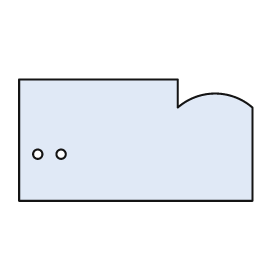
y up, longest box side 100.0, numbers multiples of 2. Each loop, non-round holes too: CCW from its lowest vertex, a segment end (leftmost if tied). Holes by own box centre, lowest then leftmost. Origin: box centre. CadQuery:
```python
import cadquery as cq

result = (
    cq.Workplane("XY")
    .moveTo(-50.0, -26.0)
    .lineTo(50.0, -26.0)
    .lineTo(50.0, 14.0)
    .threePointArc((34.0, 20.0), (18.0, 14.0))
    .lineTo(18.0, 26.0)
    .lineTo(-50.0, 26.0)
    .close()
    .moveTo(-42.0, -6.0)
    .circle(2.0)
    .moveTo(-32.0, -6.0)
    .circle(2.0)
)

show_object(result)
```